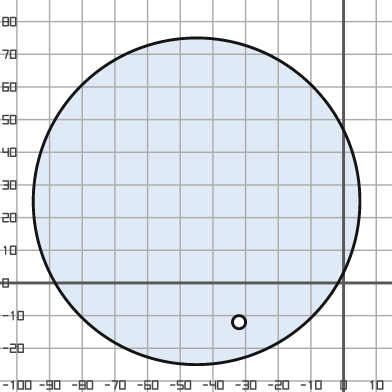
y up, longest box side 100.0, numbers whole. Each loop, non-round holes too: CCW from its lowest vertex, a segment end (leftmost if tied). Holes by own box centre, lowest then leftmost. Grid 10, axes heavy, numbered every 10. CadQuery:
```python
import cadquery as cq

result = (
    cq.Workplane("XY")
    .moveTo(-45.0, 25.0)
    .circle(50.0)
    .moveTo(-32.0, -12.0)
    .circle(2.0)
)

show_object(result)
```